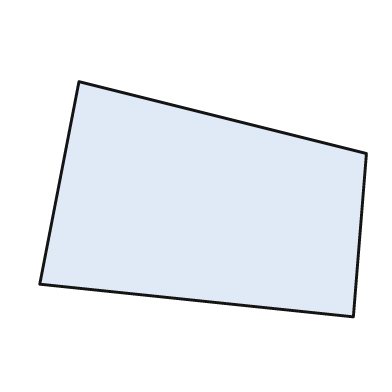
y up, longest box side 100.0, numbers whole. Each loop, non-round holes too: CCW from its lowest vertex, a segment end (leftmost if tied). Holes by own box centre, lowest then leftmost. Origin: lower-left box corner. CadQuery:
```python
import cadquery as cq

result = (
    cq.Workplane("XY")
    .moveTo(96.0, 0.0)
    .lineTo(100.0, 50.0)
    .lineTo(12.0, 72.0)
    .lineTo(0.0, 10.0)
    .close()
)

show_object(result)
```